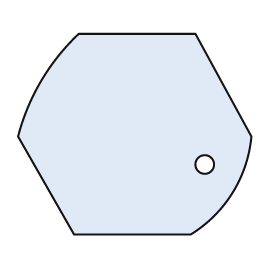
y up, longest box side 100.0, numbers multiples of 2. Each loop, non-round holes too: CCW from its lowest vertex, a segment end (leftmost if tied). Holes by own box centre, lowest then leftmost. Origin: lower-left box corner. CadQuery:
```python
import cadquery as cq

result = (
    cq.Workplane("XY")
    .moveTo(24.0, 0.0)
    .lineTo(74.0, 0.0)
    .threePointArc((92.0, 18.0), (100.0, 42.0))
    .lineTo(76.0, 86.0)
    .lineTo(26.0, 86.0)
    .threePointArc((10.0, 66.0), (0.0, 42.0))
    .close()
    .moveTo(80.0, 30.0)
    .circle(4.0)
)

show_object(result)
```